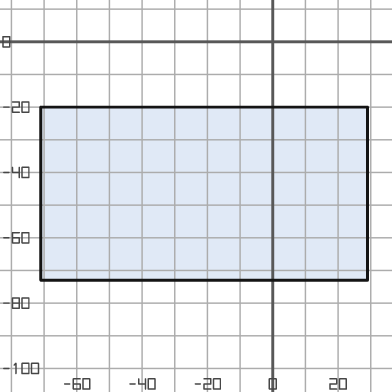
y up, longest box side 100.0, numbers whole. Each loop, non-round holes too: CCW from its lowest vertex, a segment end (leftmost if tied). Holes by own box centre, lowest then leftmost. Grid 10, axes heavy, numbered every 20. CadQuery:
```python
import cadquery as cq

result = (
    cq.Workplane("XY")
    .moveTo(-71.0, -73.0)
    .lineTo(29.0, -73.0)
    .lineTo(29.0, -20.0)
    .lineTo(-71.0, -20.0)
    .close()
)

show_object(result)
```